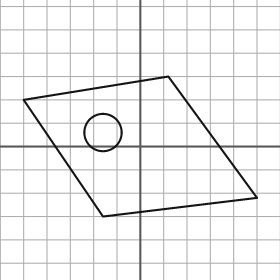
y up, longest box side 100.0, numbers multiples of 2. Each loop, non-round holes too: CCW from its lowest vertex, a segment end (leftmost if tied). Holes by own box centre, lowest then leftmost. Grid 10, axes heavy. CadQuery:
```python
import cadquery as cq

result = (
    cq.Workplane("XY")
    .moveTo(-16.0, -30.0)
    .lineTo(50.0, -22.0)
    .lineTo(12.0, 30.0)
    .lineTo(-50.0, 20.0)
    .close()
    .moveTo(-16.0, 6.0)
    .circle(8.0)
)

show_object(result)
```